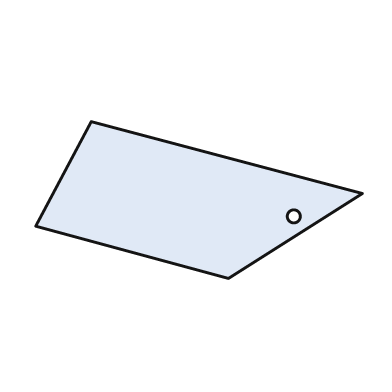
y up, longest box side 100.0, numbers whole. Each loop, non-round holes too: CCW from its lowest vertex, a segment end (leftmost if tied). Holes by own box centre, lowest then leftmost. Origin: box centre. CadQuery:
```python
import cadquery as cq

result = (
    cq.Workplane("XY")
    .moveTo(9.0, -24.0)
    .lineTo(50.0, 2.0)
    .lineTo(-33.0, 24.0)
    .lineTo(-50.0, -8.0)
    .close()
    .moveTo(29.0, -5.0)
    .circle(2.0)
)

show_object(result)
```